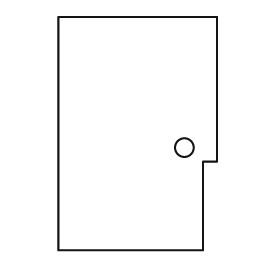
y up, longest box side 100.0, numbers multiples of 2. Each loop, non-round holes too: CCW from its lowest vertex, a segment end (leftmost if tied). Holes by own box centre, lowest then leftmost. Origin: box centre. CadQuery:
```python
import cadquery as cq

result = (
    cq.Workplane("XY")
    .moveTo(-34.0, -50.0)
    .lineTo(28.0, -50.0)
    .lineTo(28.0, -12.0)
    .lineTo(34.0, -12.0)
    .lineTo(34.0, 50.0)
    .lineTo(-34.0, 50.0)
    .close()
    .moveTo(20.0, -6.0)
    .circle(4.0)
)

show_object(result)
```